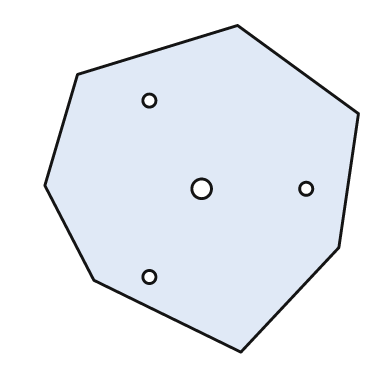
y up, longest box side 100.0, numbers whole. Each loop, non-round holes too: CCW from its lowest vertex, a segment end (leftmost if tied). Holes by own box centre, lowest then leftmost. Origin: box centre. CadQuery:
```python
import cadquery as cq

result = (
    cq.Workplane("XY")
    .moveTo(12.0, -50.0)
    .lineTo(42.0, -18.0)
    .lineTo(48.0, 23.0)
    .lineTo(11.0, 50.0)
    .lineTo(-38.0, 35.0)
    .lineTo(-48.0, 1.0)
    .lineTo(-33.0, -28.0)
    .close()
    .moveTo(-16.0, -27.0)
    .circle(2.0)
    .moveTo(0.0, 0.0)
    .circle(3.0)
    .moveTo(32.0, 0.0)
    .circle(2.0)
    .moveTo(-16.0, 27.0)
    .circle(2.0)
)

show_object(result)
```